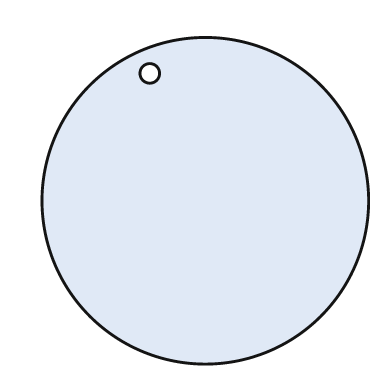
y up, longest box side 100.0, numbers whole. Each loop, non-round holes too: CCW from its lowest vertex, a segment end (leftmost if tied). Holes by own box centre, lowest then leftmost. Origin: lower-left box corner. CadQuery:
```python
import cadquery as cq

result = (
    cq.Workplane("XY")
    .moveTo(50.0, 50.0)
    .circle(50.0)
    .moveTo(33.0, 89.0)
    .circle(3.0)
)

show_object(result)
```